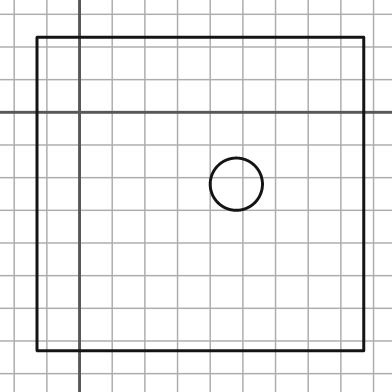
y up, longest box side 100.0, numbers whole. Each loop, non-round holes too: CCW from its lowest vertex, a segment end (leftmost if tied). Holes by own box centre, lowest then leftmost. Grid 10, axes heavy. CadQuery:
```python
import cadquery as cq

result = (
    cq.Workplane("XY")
    .moveTo(-13.0, -73.0)
    .lineTo(87.0, -73.0)
    .lineTo(87.0, 23.0)
    .lineTo(-13.0, 23.0)
    .close()
    .moveTo(48.0, -22.0)
    .circle(8.0)
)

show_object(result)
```